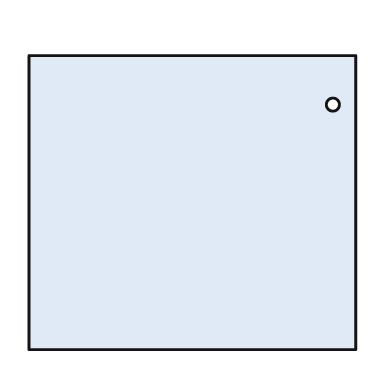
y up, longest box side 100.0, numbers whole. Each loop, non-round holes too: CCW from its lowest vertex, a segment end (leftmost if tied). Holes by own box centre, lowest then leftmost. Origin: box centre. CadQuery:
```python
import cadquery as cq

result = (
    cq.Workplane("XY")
    .moveTo(-50.0, -45.0)
    .lineTo(50.0, -45.0)
    .lineTo(50.0, 45.0)
    .lineTo(-50.0, 45.0)
    .close()
    .moveTo(43.0, 30.0)
    .circle(2.0)
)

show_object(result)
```